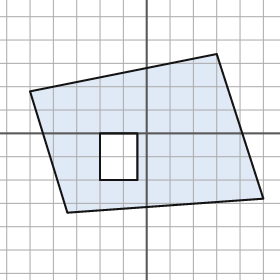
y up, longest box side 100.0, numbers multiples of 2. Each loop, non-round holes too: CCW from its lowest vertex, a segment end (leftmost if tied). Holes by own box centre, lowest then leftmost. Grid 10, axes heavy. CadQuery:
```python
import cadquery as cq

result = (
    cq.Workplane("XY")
    .moveTo(-34.0, -34.0)
    .lineTo(50.0, -28.0)
    .lineTo(30.0, 34.0)
    .lineTo(-50.0, 18.0)
    .close()
    .moveTo(-20.0, -20.0)
    .lineTo(-4.0, -20.0)
    .lineTo(-4.0, 0.0)
    .lineTo(-20.0, 0.0)
    .close()
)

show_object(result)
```